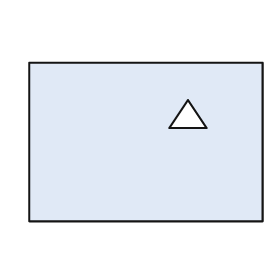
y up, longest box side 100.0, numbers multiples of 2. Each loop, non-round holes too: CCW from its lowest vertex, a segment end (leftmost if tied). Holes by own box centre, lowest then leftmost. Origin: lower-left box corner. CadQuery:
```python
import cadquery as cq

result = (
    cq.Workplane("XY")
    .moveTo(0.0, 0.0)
    .lineTo(100.0, 0.0)
    .lineTo(100.0, 68.0)
    .lineTo(0.0, 68.0)
    .close()
    .moveTo(60.0, 40.0)
    .lineTo(76.0, 40.0)
    .lineTo(68.0, 52.0)
    .close()
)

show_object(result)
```